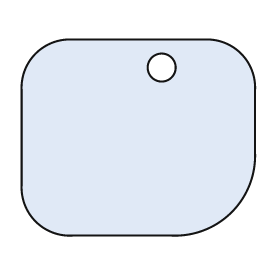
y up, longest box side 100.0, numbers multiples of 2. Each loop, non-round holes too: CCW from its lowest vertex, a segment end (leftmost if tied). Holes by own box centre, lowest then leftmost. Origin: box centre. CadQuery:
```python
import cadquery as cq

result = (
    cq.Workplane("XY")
    .moveTo(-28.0, -42.0)
    .lineTo(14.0, -42.0)
    .threePointArc((40.0, -32.0), (50.0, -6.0))
    .lineTo(50.0, 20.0)
    .threePointArc((44.0, 36.0), (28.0, 42.0))
    .lineTo(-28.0, 42.0)
    .threePointArc((-44.0, 36.0), (-50.0, 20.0))
    .lineTo(-50.0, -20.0)
    .threePointArc((-44.0, -36.0), (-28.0, -42.0))
    .close()
    .moveTo(10.0, 30.0)
    .circle(6.0)
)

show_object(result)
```